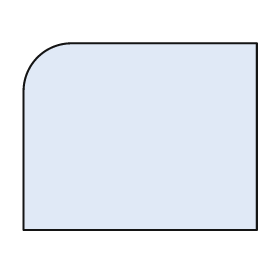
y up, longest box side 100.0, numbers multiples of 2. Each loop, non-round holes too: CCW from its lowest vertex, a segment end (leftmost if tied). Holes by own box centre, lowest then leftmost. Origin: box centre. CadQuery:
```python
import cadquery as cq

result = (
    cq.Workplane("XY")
    .moveTo(-50.0, -40.0)
    .lineTo(50.0, -40.0)
    .lineTo(50.0, 40.0)
    .lineTo(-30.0, 40.0)
    .threePointArc((-44.0, 34.0), (-50.0, 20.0))
    .close()
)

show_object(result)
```